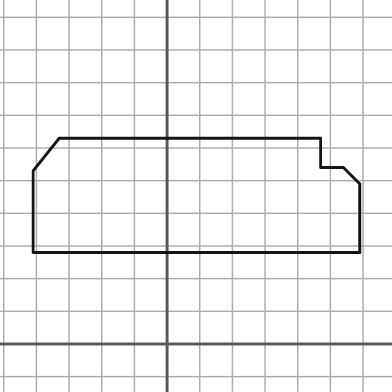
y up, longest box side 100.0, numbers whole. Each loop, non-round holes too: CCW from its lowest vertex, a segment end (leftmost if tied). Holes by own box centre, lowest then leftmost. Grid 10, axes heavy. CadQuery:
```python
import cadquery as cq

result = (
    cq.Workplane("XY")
    .moveTo(-41.0, 28.0)
    .lineTo(59.0, 28.0)
    .lineTo(59.0, 49.0)
    .lineTo(54.0, 54.0)
    .lineTo(47.0, 54.0)
    .lineTo(47.0, 63.0)
    .lineTo(-33.0, 63.0)
    .lineTo(-41.0, 53.0)
    .close()
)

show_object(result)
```